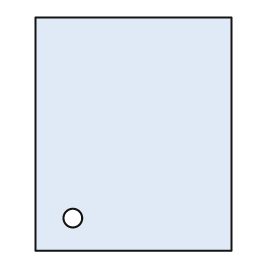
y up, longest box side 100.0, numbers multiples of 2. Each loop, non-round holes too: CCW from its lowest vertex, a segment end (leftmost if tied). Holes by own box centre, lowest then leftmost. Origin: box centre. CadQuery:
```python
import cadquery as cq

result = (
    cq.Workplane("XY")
    .moveTo(-42.0, -50.0)
    .lineTo(42.0, -50.0)
    .lineTo(42.0, 50.0)
    .lineTo(-42.0, 50.0)
    .close()
    .moveTo(-26.0, -36.0)
    .circle(4.0)
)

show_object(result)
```